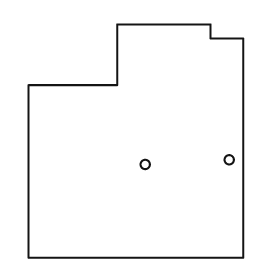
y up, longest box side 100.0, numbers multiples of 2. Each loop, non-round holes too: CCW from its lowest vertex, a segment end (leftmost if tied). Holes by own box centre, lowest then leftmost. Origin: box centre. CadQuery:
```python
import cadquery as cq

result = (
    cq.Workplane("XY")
    .moveTo(-46.0, -50.0)
    .lineTo(46.0, -50.0)
    .lineTo(46.0, 44.0)
    .lineTo(32.0, 44.0)
    .lineTo(32.0, 50.0)
    .lineTo(-8.0, 50.0)
    .lineTo(-8.0, 24.0)
    .lineTo(-46.0, 24.0)
    .close()
    .moveTo(4.0, -10.0)
    .circle(2.0)
    .moveTo(40.0, -8.0)
    .circle(2.0)
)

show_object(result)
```